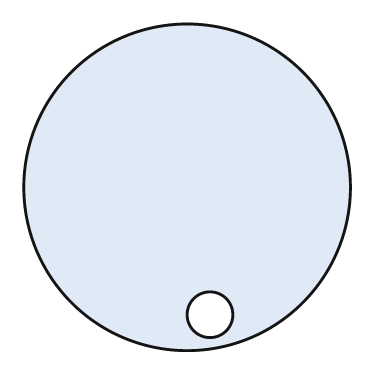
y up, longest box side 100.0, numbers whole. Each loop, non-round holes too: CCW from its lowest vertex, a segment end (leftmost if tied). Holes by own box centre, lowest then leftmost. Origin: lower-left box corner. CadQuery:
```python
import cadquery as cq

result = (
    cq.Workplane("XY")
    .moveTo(50.0, 50.0)
    .circle(50.0)
    .moveTo(57.0, 11.0)
    .circle(7.0)
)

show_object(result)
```